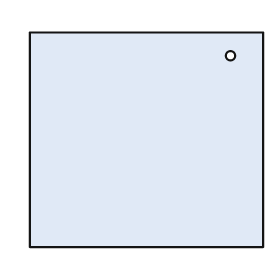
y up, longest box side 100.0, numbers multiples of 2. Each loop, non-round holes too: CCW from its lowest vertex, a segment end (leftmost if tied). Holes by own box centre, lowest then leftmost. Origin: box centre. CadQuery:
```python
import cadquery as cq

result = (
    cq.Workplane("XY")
    .moveTo(-50.0, -46.0)
    .lineTo(50.0, -46.0)
    .lineTo(50.0, 46.0)
    .lineTo(-50.0, 46.0)
    .close()
    .moveTo(36.0, 36.0)
    .circle(2.0)
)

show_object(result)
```